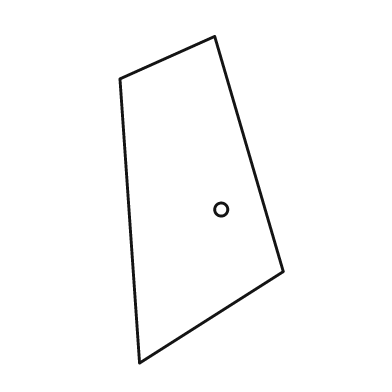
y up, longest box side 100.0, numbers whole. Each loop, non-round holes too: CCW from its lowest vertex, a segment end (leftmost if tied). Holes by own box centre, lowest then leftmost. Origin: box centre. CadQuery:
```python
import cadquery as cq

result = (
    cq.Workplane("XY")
    .moveTo(-19.0, -50.0)
    .lineTo(25.0, -22.0)
    .lineTo(4.0, 50.0)
    .lineTo(-25.0, 37.0)
    .close()
    .moveTo(6.0, -3.0)
    .circle(2.0)
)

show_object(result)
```